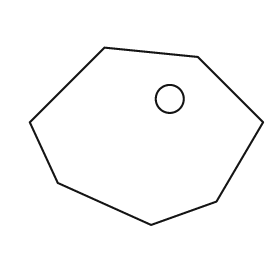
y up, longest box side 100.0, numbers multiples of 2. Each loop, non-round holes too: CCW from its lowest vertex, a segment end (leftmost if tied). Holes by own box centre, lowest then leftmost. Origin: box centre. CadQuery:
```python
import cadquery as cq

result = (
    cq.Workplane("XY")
    .moveTo(2.0, -38.0)
    .lineTo(30.0, -28.0)
    .lineTo(50.0, 6.0)
    .lineTo(22.0, 34.0)
    .lineTo(-18.0, 38.0)
    .lineTo(-50.0, 6.0)
    .lineTo(-38.0, -20.0)
    .close()
    .moveTo(10.0, 16.0)
    .circle(6.0)
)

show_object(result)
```